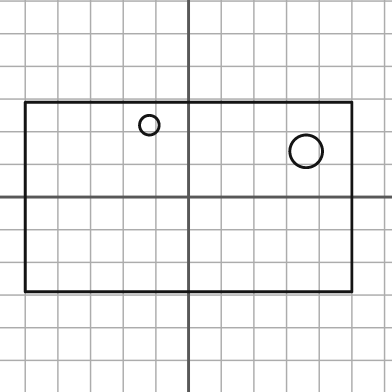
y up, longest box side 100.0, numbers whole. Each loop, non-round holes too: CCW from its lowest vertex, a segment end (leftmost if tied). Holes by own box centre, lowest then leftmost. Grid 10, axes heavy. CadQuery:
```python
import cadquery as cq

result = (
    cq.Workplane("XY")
    .moveTo(-50.0, -29.0)
    .lineTo(50.0, -29.0)
    .lineTo(50.0, 29.0)
    .lineTo(-50.0, 29.0)
    .close()
    .moveTo(36.0, 14.0)
    .circle(5.0)
    .moveTo(-12.0, 22.0)
    .circle(3.0)
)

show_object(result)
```